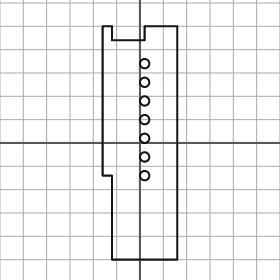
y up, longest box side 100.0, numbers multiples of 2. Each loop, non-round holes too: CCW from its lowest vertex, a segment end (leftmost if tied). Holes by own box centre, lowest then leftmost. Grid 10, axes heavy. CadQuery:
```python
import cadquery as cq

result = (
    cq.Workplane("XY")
    .moveTo(-12.0, -50.0)
    .lineTo(16.0, -50.0)
    .lineTo(16.0, 50.0)
    .lineTo(2.0, 50.0)
    .lineTo(2.0, 44.0)
    .lineTo(-12.0, 44.0)
    .lineTo(-12.0, 50.0)
    .lineTo(-16.0, 50.0)
    .lineTo(-16.0, -14.0)
    .lineTo(-12.0, -14.0)
    .close()
    .moveTo(2.0, -14.0)
    .circle(2.0)
    .moveTo(2.0, -6.0)
    .circle(2.0)
    .moveTo(2.0, 2.0)
    .circle(2.0)
    .moveTo(2.0, 10.0)
    .circle(2.0)
    .moveTo(2.0, 18.0)
    .circle(2.0)
    .moveTo(2.0, 26.0)
    .circle(2.0)
    .moveTo(2.0, 34.0)
    .circle(2.0)
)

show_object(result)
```